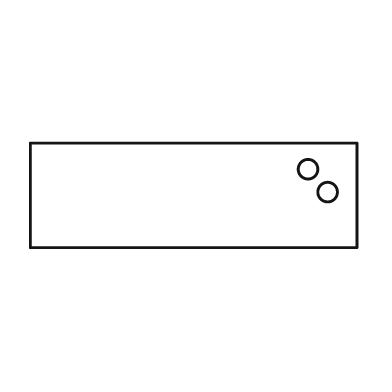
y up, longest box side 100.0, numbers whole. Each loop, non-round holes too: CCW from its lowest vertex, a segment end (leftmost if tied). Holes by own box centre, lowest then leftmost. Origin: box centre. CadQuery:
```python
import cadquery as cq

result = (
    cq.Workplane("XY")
    .moveTo(-50.0, -16.0)
    .lineTo(50.0, -16.0)
    .lineTo(50.0, 16.0)
    .lineTo(-50.0, 16.0)
    .close()
    .moveTo(41.0, 1.0)
    .circle(3.0)
    .moveTo(35.0, 8.0)
    .circle(3.0)
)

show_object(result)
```